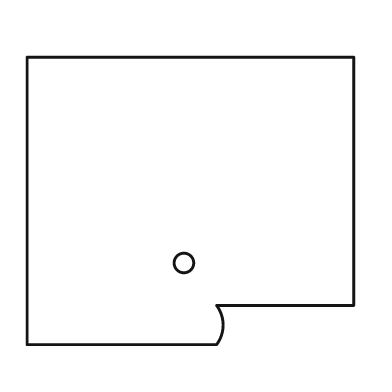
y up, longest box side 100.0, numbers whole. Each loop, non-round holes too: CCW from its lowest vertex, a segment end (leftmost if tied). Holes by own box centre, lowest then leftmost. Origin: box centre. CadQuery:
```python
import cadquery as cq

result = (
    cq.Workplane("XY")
    .moveTo(-50.0, -44.0)
    .lineTo(8.0, -44.0)
    .threePointArc((10.0, -38.0), (8.0, -32.0))
    .lineTo(50.0, -32.0)
    .lineTo(50.0, 44.0)
    .lineTo(-50.0, 44.0)
    .close()
    .moveTo(-2.0, -19.0)
    .circle(3.0)
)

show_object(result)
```